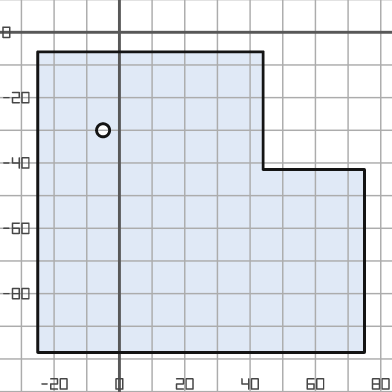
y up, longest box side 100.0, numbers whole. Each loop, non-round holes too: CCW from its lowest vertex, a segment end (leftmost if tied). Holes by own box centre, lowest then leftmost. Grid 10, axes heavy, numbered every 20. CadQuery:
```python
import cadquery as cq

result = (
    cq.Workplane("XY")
    .moveTo(-25.0, -98.0)
    .lineTo(75.0, -98.0)
    .lineTo(75.0, -42.0)
    .lineTo(44.0, -42.0)
    .lineTo(44.0, -6.0)
    .lineTo(-25.0, -6.0)
    .close()
    .moveTo(-5.0, -30.0)
    .circle(2.0)
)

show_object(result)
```